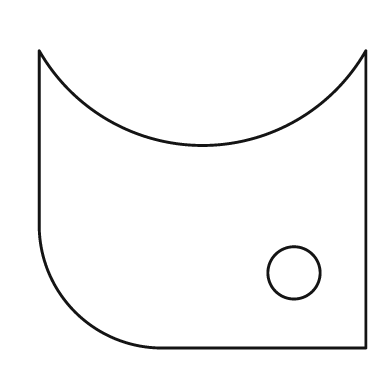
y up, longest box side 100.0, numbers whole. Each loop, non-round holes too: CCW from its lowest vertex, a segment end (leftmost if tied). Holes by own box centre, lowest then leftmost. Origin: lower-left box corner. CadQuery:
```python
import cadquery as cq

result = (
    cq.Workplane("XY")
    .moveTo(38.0, 0.0)
    .lineTo(100.0, 0.0)
    .lineTo(100.0, 91.0)
    .threePointArc((50.0, 62.0), (0.0, 91.0))
    .lineTo(0.0, 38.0)
    .threePointArc((11.0, 11.0), (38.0, 0.0))
    .close()
    .moveTo(78.0, 23.0)
    .circle(8.0)
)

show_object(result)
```